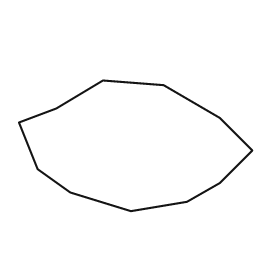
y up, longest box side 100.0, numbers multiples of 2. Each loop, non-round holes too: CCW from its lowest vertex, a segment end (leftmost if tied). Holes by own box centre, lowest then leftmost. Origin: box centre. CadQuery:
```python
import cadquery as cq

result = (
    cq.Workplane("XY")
    .moveTo(-2.0, -28.0)
    .lineTo(22.0, -24.0)
    .lineTo(36.0, -16.0)
    .lineTo(50.0, -2.0)
    .lineTo(36.0, 12.0)
    .lineTo(12.0, 26.0)
    .lineTo(-14.0, 28.0)
    .lineTo(-34.0, 16.0)
    .lineTo(-50.0, 10.0)
    .lineTo(-42.0, -10.0)
    .lineTo(-28.0, -20.0)
    .close()
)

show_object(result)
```